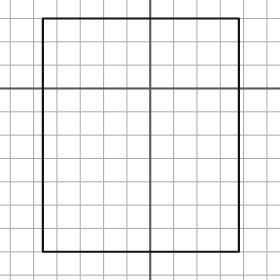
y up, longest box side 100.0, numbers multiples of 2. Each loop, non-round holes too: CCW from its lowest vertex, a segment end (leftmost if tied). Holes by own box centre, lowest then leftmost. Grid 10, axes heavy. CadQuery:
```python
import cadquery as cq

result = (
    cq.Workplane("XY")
    .moveTo(-46.0, -70.0)
    .lineTo(38.0, -70.0)
    .lineTo(38.0, 30.0)
    .lineTo(-46.0, 30.0)
    .close()
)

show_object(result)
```